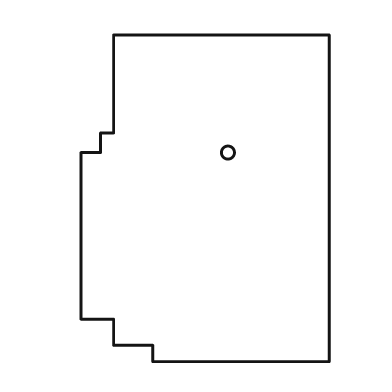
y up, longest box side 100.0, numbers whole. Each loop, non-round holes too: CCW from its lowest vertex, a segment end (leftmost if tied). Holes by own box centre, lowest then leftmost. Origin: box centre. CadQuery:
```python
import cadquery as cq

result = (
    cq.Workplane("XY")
    .moveTo(-16.0, -50.0)
    .lineTo(38.0, -50.0)
    .lineTo(38.0, 50.0)
    .lineTo(-28.0, 50.0)
    .lineTo(-28.0, 20.0)
    .lineTo(-32.0, 20.0)
    .lineTo(-32.0, 14.0)
    .lineTo(-38.0, 14.0)
    .lineTo(-38.0, -37.0)
    .lineTo(-28.0, -37.0)
    .lineTo(-28.0, -45.0)
    .lineTo(-16.0, -45.0)
    .close()
    .moveTo(7.0, 14.0)
    .circle(2.0)
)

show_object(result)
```